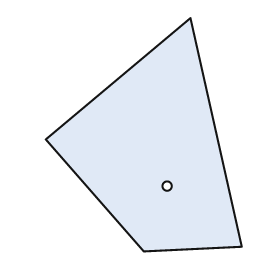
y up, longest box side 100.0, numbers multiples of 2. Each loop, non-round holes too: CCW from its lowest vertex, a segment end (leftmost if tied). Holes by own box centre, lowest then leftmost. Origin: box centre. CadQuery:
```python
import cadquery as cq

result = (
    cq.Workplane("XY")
    .moveTo(0.0, -50.0)
    .lineTo(42.0, -48.0)
    .lineTo(20.0, 50.0)
    .lineTo(-42.0, -2.0)
    .close()
    .moveTo(10.0, -22.0)
    .circle(2.0)
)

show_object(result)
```